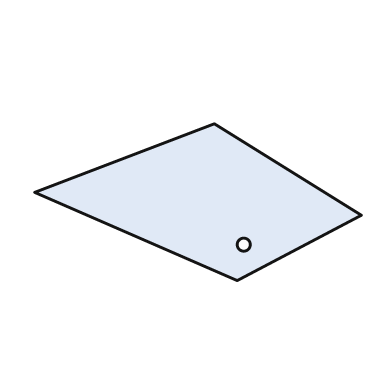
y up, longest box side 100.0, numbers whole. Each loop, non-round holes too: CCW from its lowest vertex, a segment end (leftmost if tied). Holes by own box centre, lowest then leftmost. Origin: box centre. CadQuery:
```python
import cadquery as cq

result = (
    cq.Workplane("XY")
    .moveTo(12.0, -24.0)
    .lineTo(50.0, -4.0)
    .lineTo(5.0, 24.0)
    .lineTo(-50.0, 3.0)
    .close()
    .moveTo(14.0, -13.0)
    .circle(2.0)
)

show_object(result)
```